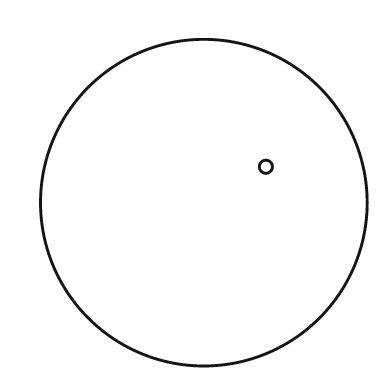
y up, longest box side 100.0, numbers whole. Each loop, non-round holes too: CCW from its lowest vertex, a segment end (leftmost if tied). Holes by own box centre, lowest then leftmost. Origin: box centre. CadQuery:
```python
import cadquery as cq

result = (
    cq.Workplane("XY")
    .moveTo(0.0, 0.0)
    .circle(50.0)
    .moveTo(19.0, 11.0)
    .circle(2.0)
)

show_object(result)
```